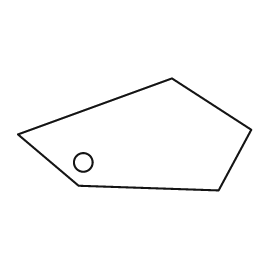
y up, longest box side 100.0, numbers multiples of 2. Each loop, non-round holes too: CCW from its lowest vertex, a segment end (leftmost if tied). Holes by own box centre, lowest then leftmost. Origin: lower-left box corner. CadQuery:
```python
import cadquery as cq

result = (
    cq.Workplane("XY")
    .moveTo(86.0, 0.0)
    .lineTo(100.0, 26.0)
    .lineTo(66.0, 48.0)
    .lineTo(0.0, 24.0)
    .lineTo(26.0, 2.0)
    .close()
    .moveTo(28.0, 12.0)
    .circle(4.0)
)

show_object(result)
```